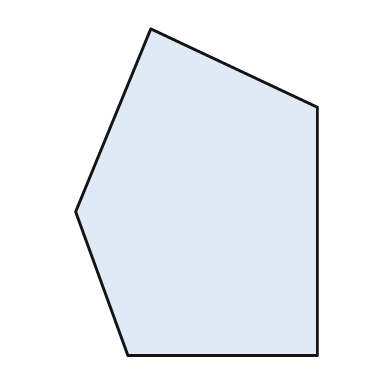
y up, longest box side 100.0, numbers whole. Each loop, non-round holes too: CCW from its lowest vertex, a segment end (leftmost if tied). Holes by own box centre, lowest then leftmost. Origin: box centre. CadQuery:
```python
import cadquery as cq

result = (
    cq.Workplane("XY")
    .moveTo(-21.0, -50.0)
    .lineTo(37.0, -50.0)
    .lineTo(37.0, 26.0)
    .lineTo(-14.0, 50.0)
    .lineTo(-37.0, -6.0)
    .close()
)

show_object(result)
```